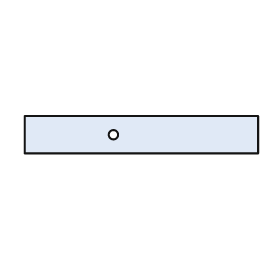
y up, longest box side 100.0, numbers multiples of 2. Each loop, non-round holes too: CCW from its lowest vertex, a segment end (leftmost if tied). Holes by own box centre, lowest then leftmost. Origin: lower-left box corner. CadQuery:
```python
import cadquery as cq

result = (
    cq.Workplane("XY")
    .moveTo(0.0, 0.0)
    .lineTo(100.0, 0.0)
    .lineTo(100.0, 16.0)
    .lineTo(0.0, 16.0)
    .close()
    .moveTo(38.0, 8.0)
    .circle(2.0)
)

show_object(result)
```